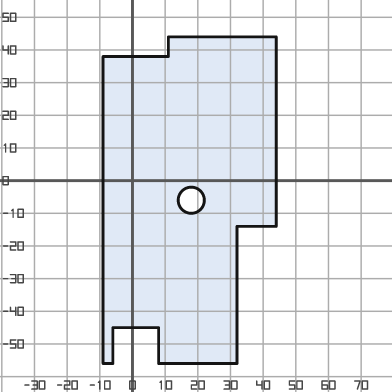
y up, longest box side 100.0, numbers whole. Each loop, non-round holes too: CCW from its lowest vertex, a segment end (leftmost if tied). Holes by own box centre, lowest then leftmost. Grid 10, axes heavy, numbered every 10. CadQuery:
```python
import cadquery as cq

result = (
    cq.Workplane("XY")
    .moveTo(-9.0, -56.0)
    .lineTo(-6.0, -56.0)
    .lineTo(-6.0, -45.0)
    .lineTo(8.0, -45.0)
    .lineTo(8.0, -56.0)
    .lineTo(32.0, -56.0)
    .lineTo(32.0, -14.0)
    .lineTo(44.0, -14.0)
    .lineTo(44.0, 44.0)
    .lineTo(11.0, 44.0)
    .lineTo(11.0, 38.0)
    .lineTo(-9.0, 38.0)
    .close()
    .moveTo(18.0, -6.0)
    .circle(4.0)
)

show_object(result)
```